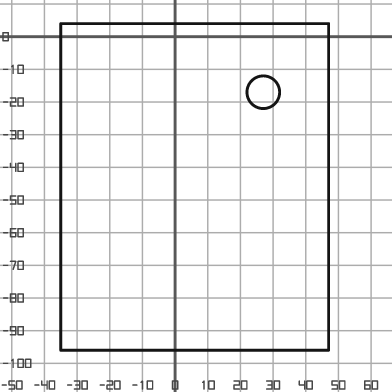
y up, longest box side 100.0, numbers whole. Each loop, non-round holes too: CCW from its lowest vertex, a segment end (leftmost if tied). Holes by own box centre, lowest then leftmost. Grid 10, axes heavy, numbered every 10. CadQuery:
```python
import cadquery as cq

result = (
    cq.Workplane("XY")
    .moveTo(-35.0, -96.0)
    .lineTo(47.0, -96.0)
    .lineTo(47.0, 4.0)
    .lineTo(-35.0, 4.0)
    .close()
    .moveTo(27.0, -17.0)
    .circle(5.0)
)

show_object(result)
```